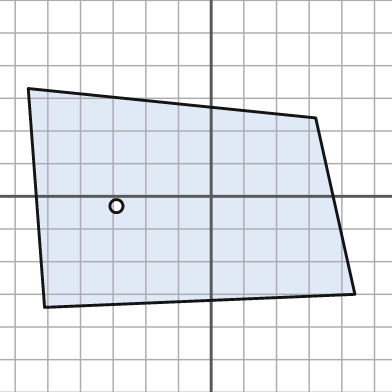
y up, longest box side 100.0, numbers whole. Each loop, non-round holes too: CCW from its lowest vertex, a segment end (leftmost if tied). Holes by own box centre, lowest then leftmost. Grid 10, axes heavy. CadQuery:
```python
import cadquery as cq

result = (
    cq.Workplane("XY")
    .moveTo(-51.0, -34.0)
    .lineTo(44.0, -30.0)
    .lineTo(32.0, 24.0)
    .lineTo(-56.0, 33.0)
    .close()
    .moveTo(-29.0, -3.0)
    .circle(2.0)
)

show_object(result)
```